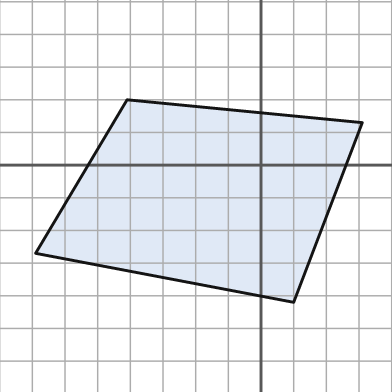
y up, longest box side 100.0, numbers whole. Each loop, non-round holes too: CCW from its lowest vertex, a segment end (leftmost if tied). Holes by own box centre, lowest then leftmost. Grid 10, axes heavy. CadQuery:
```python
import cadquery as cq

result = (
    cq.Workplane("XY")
    .moveTo(10.0, -42.0)
    .lineTo(31.0, 13.0)
    .lineTo(-41.0, 20.0)
    .lineTo(-69.0, -27.0)
    .close()
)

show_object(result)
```